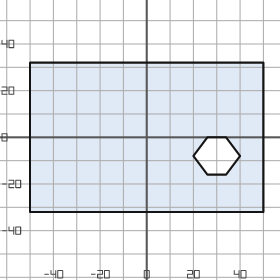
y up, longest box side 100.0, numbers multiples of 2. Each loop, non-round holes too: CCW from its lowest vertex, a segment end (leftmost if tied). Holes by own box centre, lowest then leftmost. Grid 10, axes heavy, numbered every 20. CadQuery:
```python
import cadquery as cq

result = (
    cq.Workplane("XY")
    .moveTo(-50.0, -32.0)
    .lineTo(50.0, -32.0)
    .lineTo(50.0, 32.0)
    .lineTo(-50.0, 32.0)
    .close()
    .moveTo(26.0, -16.0)
    .lineTo(34.0, -16.0)
    .lineTo(40.0, -8.0)
    .lineTo(34.0, 0.0)
    .lineTo(26.0, 0.0)
    .lineTo(20.0, -8.0)
    .close()
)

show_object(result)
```